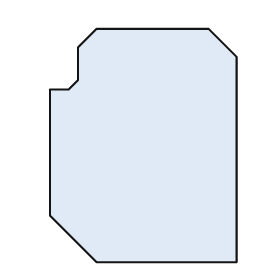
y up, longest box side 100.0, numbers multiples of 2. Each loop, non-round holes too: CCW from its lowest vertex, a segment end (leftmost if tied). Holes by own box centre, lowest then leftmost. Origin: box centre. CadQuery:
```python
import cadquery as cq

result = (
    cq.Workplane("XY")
    .moveTo(-20.0, -50.0)
    .lineTo(40.0, -50.0)
    .lineTo(40.0, 38.0)
    .lineTo(28.0, 50.0)
    .lineTo(-20.0, 50.0)
    .lineTo(-28.0, 42.0)
    .lineTo(-28.0, 28.0)
    .lineTo(-32.0, 24.0)
    .lineTo(-40.0, 24.0)
    .lineTo(-40.0, -30.0)
    .close()
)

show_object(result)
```